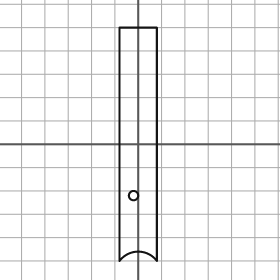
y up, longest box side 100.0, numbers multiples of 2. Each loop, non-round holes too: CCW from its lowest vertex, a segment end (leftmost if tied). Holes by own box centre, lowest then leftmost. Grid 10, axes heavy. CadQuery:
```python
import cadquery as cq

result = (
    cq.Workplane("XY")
    .moveTo(-8.0, -50.0)
    .threePointArc((0.0, -46.0), (8.0, -50.0))
    .lineTo(8.0, 50.0)
    .lineTo(-8.0, 50.0)
    .close()
    .moveTo(-2.0, -22.0)
    .circle(2.0)
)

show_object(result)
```